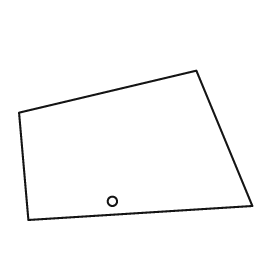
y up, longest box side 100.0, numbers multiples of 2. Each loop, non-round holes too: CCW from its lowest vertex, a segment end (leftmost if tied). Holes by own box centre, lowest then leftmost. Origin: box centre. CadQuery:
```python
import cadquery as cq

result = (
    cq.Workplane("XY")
    .moveTo(-46.0, -32.0)
    .lineTo(50.0, -26.0)
    .lineTo(26.0, 32.0)
    .lineTo(-50.0, 14.0)
    .close()
    .moveTo(-10.0, -24.0)
    .circle(2.0)
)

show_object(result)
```